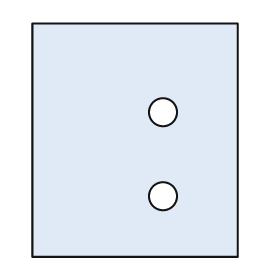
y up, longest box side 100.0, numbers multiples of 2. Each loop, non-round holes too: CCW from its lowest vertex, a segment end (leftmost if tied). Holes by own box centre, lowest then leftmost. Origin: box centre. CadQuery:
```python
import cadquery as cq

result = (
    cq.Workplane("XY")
    .moveTo(-44.0, -50.0)
    .lineTo(44.0, -50.0)
    .lineTo(44.0, 50.0)
    .lineTo(-44.0, 50.0)
    .close()
    .moveTo(12.0, -24.0)
    .circle(6.0)
    .moveTo(12.0, 12.0)
    .circle(6.0)
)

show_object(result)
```